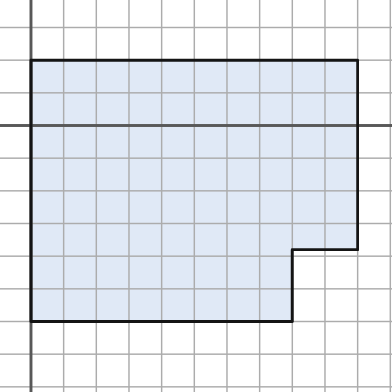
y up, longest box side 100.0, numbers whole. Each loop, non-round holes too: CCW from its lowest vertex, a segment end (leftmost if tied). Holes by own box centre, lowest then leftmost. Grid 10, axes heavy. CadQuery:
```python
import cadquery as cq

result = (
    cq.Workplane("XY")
    .moveTo(0.0, -60.0)
    .lineTo(80.0, -60.0)
    .lineTo(80.0, -38.0)
    .lineTo(100.0, -38.0)
    .lineTo(100.0, 20.0)
    .lineTo(0.0, 20.0)
    .close()
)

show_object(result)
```